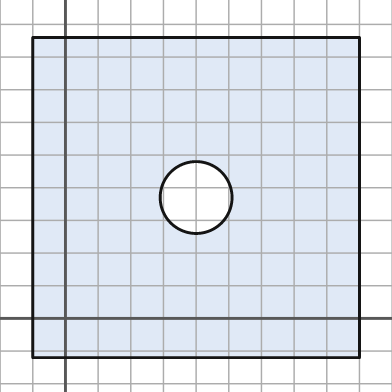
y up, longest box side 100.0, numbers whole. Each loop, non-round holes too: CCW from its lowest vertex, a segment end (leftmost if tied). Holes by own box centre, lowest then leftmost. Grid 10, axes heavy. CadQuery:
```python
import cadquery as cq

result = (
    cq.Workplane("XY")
    .moveTo(-10.0, -12.0)
    .lineTo(90.0, -12.0)
    .lineTo(90.0, 86.0)
    .lineTo(-10.0, 86.0)
    .close()
    .moveTo(40.0, 37.0)
    .circle(11.0)
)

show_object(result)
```